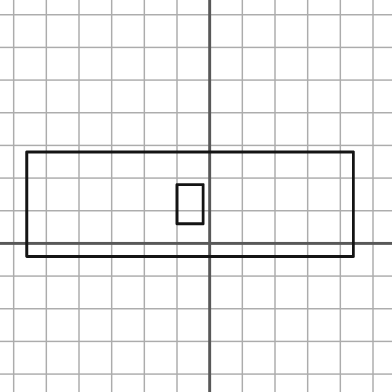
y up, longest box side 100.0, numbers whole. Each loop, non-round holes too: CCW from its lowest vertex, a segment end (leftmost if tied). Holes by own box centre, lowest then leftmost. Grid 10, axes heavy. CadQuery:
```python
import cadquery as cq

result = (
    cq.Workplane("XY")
    .moveTo(-56.0, -4.0)
    .lineTo(44.0, -4.0)
    .lineTo(44.0, 28.0)
    .lineTo(-56.0, 28.0)
    .close()
    .moveTo(-10.0, 6.0)
    .lineTo(-2.0, 6.0)
    .lineTo(-2.0, 18.0)
    .lineTo(-10.0, 18.0)
    .close()
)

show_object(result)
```